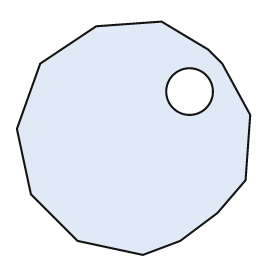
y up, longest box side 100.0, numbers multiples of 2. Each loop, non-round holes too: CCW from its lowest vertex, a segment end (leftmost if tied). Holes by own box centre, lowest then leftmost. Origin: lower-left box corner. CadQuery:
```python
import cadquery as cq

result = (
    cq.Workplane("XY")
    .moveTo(54.0, 0.0)
    .lineTo(70.0, 6.0)
    .lineTo(86.0, 18.0)
    .lineTo(98.0, 32.0)
    .lineTo(100.0, 60.0)
    .lineTo(88.0, 82.0)
    .lineTo(82.0, 88.0)
    .lineTo(62.0, 100.0)
    .lineTo(34.0, 98.0)
    .lineTo(10.0, 82.0)
    .lineTo(0.0, 54.0)
    .lineTo(6.0, 26.0)
    .lineTo(26.0, 6.0)
    .close()
    .moveTo(74.0, 70.0)
    .circle(10.0)
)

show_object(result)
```